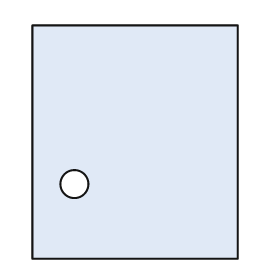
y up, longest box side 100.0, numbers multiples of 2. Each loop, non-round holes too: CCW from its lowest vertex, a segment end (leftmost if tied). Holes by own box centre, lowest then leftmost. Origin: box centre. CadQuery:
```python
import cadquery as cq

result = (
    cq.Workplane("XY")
    .moveTo(-44.0, -50.0)
    .lineTo(44.0, -50.0)
    .lineTo(44.0, 50.0)
    .lineTo(-44.0, 50.0)
    .close()
    .moveTo(-26.0, -18.0)
    .circle(6.0)
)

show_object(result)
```